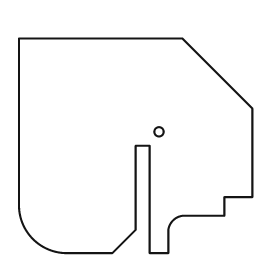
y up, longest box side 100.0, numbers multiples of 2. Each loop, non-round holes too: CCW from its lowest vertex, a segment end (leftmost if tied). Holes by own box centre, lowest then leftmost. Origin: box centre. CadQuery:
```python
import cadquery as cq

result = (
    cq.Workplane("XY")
    .moveTo(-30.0, -46.0)
    .lineTo(-10.0, -46.0)
    .lineTo(0.0, -36.0)
    .lineTo(0.0, 0.0)
    .lineTo(6.0, 0.0)
    .lineTo(6.0, -46.0)
    .lineTo(14.0, -46.0)
    .lineTo(14.0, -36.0)
    .threePointArc((16.0, -32.0), (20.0, -30.0))
    .lineTo(38.0, -30.0)
    .lineTo(38.0, -22.0)
    .lineTo(50.0, -22.0)
    .lineTo(50.0, 16.0)
    .lineTo(20.0, 46.0)
    .lineTo(-50.0, 46.0)
    .lineTo(-50.0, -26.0)
    .threePointArc((-44.0, -40.0), (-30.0, -46.0))
    .close()
    .moveTo(10.0, 6.0)
    .circle(2.0)
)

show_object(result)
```